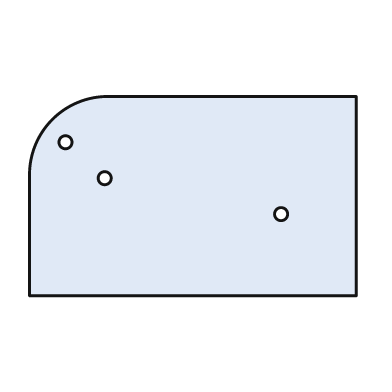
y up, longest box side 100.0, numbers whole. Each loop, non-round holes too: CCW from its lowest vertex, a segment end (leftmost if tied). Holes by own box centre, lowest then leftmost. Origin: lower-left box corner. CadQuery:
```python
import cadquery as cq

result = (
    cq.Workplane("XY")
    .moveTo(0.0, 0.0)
    .lineTo(100.0, 0.0)
    .lineTo(100.0, 61.0)
    .lineTo(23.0, 61.0)
    .threePointArc((7.0, 54.0), (0.0, 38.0))
    .close()
    .moveTo(77.0, 25.0)
    .circle(2.0)
    .moveTo(23.0, 36.0)
    .circle(2.0)
    .moveTo(11.0, 47.0)
    .circle(2.0)
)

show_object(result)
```